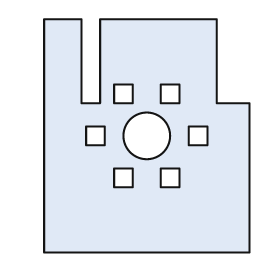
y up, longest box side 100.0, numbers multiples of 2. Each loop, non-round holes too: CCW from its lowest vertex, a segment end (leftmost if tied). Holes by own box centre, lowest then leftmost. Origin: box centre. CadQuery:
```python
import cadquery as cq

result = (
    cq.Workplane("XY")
    .moveTo(-44.0, -50.0)
    .lineTo(44.0, -50.0)
    .lineTo(44.0, 14.0)
    .lineTo(30.0, 14.0)
    .lineTo(30.0, 50.0)
    .lineTo(-20.0, 50.0)
    .lineTo(-20.0, 14.0)
    .lineTo(-28.0, 14.0)
    .lineTo(-28.0, 50.0)
    .lineTo(-44.0, 50.0)
    .close()
    .moveTo(-14.0, -22.0)
    .lineTo(-6.0, -22.0)
    .lineTo(-6.0, -14.0)
    .lineTo(-14.0, -14.0)
    .close()
    .moveTo(6.0, -22.0)
    .lineTo(14.0, -22.0)
    .lineTo(14.0, -14.0)
    .lineTo(6.0, -14.0)
    .close()
    .moveTo(-26.0, -4.0)
    .lineTo(-18.0, -4.0)
    .lineTo(-18.0, 4.0)
    .lineTo(-26.0, 4.0)
    .close()
    .moveTo(0.0, 0.0)
    .circle(10.0)
    .moveTo(18.0, -4.0)
    .lineTo(26.0, -4.0)
    .lineTo(26.0, 4.0)
    .lineTo(18.0, 4.0)
    .close()
    .moveTo(-14.0, 14.0)
    .lineTo(-6.0, 14.0)
    .lineTo(-6.0, 22.0)
    .lineTo(-14.0, 22.0)
    .close()
    .moveTo(6.0, 14.0)
    .lineTo(14.0, 14.0)
    .lineTo(14.0, 22.0)
    .lineTo(6.0, 22.0)
    .close()
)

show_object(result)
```